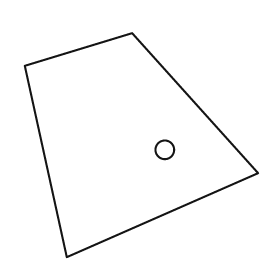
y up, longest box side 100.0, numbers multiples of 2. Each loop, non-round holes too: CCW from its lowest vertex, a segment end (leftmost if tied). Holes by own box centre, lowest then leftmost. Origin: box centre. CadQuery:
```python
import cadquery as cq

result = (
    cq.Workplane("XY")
    .moveTo(-32.0, -48.0)
    .lineTo(50.0, -12.0)
    .lineTo(-4.0, 48.0)
    .lineTo(-50.0, 34.0)
    .close()
    .moveTo(10.0, -2.0)
    .circle(4.0)
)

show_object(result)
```